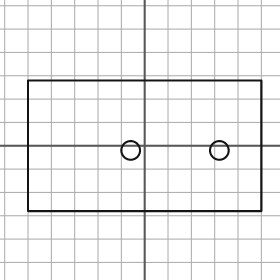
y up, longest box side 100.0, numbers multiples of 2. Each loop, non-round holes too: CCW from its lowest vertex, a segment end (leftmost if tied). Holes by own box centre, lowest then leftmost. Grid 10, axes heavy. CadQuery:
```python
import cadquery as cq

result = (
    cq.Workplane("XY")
    .moveTo(-50.0, -28.0)
    .lineTo(50.0, -28.0)
    .lineTo(50.0, 28.0)
    .lineTo(-50.0, 28.0)
    .close()
    .moveTo(-6.0, -2.0)
    .circle(4.0)
    .moveTo(32.0, -2.0)
    .circle(4.0)
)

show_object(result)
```